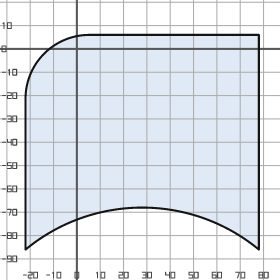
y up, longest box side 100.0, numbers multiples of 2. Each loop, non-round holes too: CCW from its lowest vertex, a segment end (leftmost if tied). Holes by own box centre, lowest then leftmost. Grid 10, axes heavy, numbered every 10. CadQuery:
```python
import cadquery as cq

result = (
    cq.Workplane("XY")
    .moveTo(-22.0, -86.0)
    .threePointArc((28.0, -68.0), (78.0, -86.0))
    .lineTo(78.0, 6.0)
    .lineTo(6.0, 6.0)
    .threePointArc((-14.0, -2.0), (-22.0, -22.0))
    .close()
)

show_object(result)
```